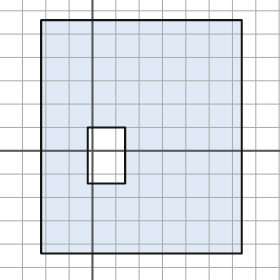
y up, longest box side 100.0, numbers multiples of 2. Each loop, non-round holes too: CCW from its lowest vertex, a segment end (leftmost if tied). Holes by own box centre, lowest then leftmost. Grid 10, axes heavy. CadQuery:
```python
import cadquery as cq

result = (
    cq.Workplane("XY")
    .moveTo(-22.0, -44.0)
    .lineTo(64.0, -44.0)
    .lineTo(64.0, 56.0)
    .lineTo(-22.0, 56.0)
    .close()
    .moveTo(-2.0, -14.0)
    .lineTo(14.0, -14.0)
    .lineTo(14.0, 10.0)
    .lineTo(-2.0, 10.0)
    .close()
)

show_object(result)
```